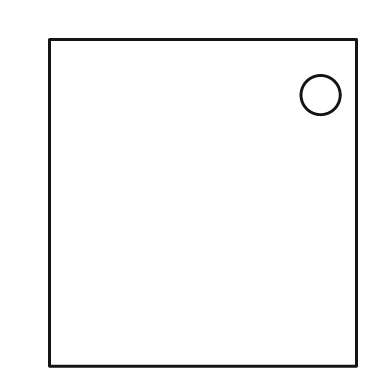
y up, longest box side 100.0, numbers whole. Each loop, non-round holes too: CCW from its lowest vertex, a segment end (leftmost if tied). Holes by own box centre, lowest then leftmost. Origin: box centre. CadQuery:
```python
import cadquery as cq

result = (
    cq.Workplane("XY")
    .moveTo(-47.0, -50.0)
    .lineTo(47.0, -50.0)
    .lineTo(47.0, 50.0)
    .lineTo(-47.0, 50.0)
    .close()
    .moveTo(36.0, 33.0)
    .circle(6.0)
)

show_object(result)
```